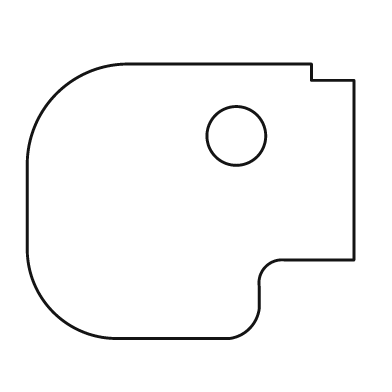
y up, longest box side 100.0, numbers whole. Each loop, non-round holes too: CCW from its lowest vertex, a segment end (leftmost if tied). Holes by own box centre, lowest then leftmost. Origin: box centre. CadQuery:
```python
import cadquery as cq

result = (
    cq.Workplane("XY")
    .moveTo(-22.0, -42.0)
    .lineTo(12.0, -42.0)
    .threePointArc((18.0, -39.0), (21.0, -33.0))
    .lineTo(21.0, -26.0)
    .threePointArc((23.0, -20.0), (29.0, -18.0))
    .lineTo(50.0, -18.0)
    .lineTo(50.0, 37.0)
    .lineTo(37.0, 37.0)
    .lineTo(37.0, 42.0)
    .lineTo(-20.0, 42.0)
    .threePointArc((-41.0, 33.0), (-50.0, 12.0))
    .lineTo(-50.0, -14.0)
    .threePointArc((-42.0, -34.0), (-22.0, -42.0))
    .close()
    .moveTo(14.0, 20.0)
    .circle(9.0)
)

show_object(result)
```